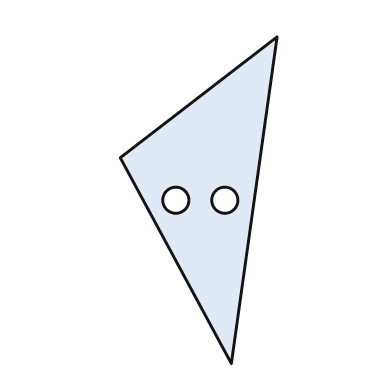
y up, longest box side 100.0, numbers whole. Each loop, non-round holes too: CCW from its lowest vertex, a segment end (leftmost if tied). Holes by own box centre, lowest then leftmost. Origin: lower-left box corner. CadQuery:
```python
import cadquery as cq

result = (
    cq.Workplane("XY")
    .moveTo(34.0, 0.0)
    .lineTo(48.0, 100.0)
    .lineTo(0.0, 63.0)
    .close()
    .moveTo(17.0, 50.0)
    .circle(4.0)
    .moveTo(32.0, 50.0)
    .circle(4.0)
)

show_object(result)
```